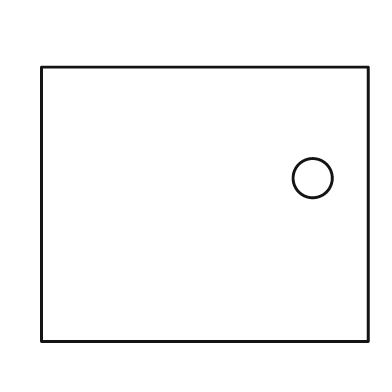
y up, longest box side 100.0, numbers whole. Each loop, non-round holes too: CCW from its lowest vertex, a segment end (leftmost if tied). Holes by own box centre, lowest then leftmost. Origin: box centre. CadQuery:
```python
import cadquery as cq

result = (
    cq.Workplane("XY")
    .moveTo(-50.0, -42.0)
    .lineTo(50.0, -42.0)
    .lineTo(50.0, 42.0)
    .lineTo(-50.0, 42.0)
    .close()
    .moveTo(33.0, 8.0)
    .circle(6.0)
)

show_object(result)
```